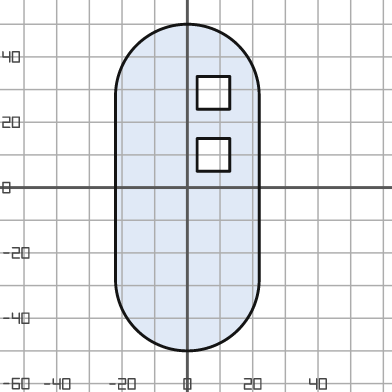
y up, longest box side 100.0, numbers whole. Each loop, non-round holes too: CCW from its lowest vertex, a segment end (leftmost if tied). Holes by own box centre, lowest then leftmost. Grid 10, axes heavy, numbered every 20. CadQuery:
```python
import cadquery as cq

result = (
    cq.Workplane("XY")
    .moveTo(-22.0, -28.0)
    .threePointArc((0.0, -50.0), (22.0, -28.0))
    .lineTo(22.0, 28.0)
    .threePointArc((0.0, 50.0), (-22.0, 28.0))
    .close()
    .moveTo(3.0, 5.0)
    .lineTo(13.0, 5.0)
    .lineTo(13.0, 15.0)
    .lineTo(3.0, 15.0)
    .close()
    .moveTo(3.0, 24.0)
    .lineTo(13.0, 24.0)
    .lineTo(13.0, 34.0)
    .lineTo(3.0, 34.0)
    .close()
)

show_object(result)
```